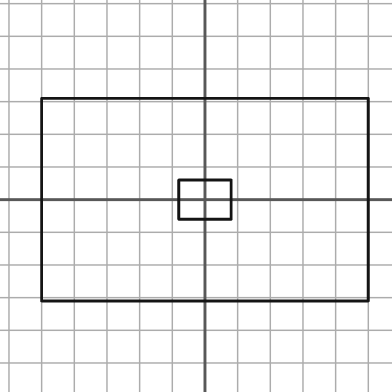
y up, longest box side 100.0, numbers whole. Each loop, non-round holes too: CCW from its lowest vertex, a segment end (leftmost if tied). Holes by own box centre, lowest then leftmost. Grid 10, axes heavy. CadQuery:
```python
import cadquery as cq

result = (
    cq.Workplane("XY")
    .moveTo(-50.0, -31.0)
    .lineTo(50.0, -31.0)
    .lineTo(50.0, 31.0)
    .lineTo(-50.0, 31.0)
    .close()
    .moveTo(-8.0, -6.0)
    .lineTo(8.0, -6.0)
    .lineTo(8.0, 6.0)
    .lineTo(-8.0, 6.0)
    .close()
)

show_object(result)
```